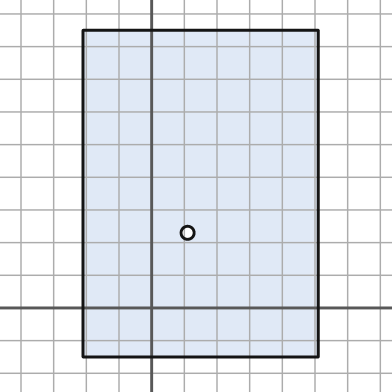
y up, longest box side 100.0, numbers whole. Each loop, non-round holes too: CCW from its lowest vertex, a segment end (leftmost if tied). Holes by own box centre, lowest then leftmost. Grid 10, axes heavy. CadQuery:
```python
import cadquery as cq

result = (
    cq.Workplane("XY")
    .moveTo(-21.0, -15.0)
    .lineTo(51.0, -15.0)
    .lineTo(51.0, 85.0)
    .lineTo(-21.0, 85.0)
    .close()
    .moveTo(11.0, 23.0)
    .circle(2.0)
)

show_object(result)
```